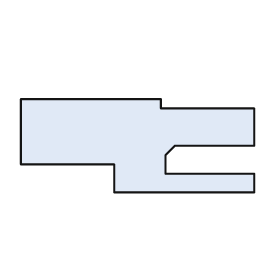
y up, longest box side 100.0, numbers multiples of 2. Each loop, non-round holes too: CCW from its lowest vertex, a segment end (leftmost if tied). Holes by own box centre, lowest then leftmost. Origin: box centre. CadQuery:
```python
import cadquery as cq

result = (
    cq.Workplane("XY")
    .moveTo(-10.0, -20.0)
    .lineTo(50.0, -20.0)
    .lineTo(50.0, -12.0)
    .lineTo(12.0, -12.0)
    .lineTo(12.0, -4.0)
    .lineTo(16.0, 0.0)
    .lineTo(50.0, 0.0)
    .lineTo(50.0, 16.0)
    .lineTo(10.0, 16.0)
    .lineTo(10.0, 20.0)
    .lineTo(-50.0, 20.0)
    .lineTo(-50.0, -8.0)
    .lineTo(-10.0, -8.0)
    .close()
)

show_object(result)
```